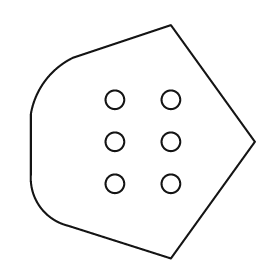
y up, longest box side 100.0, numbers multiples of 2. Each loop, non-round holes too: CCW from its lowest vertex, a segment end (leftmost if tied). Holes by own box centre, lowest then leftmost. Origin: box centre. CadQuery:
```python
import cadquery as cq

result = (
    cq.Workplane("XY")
    .moveTo(12.0, -50.0)
    .lineTo(48.0, 0.0)
    .lineTo(12.0, 50.0)
    .lineTo(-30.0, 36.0)
    .threePointArc((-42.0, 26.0), (-48.0, 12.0))
    .lineTo(-48.0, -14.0)
    .threePointArc((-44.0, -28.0), (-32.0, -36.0))
    .close()
    .moveTo(-12.0, -18.0)
    .circle(4.0)
    .moveTo(12.0, -18.0)
    .circle(4.0)
    .moveTo(-12.0, 0.0)
    .circle(4.0)
    .moveTo(12.0, 0.0)
    .circle(4.0)
    .moveTo(-12.0, 18.0)
    .circle(4.0)
    .moveTo(12.0, 18.0)
    .circle(4.0)
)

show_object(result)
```